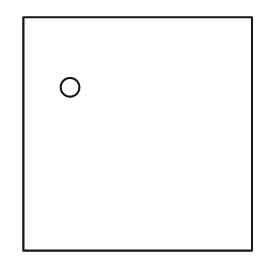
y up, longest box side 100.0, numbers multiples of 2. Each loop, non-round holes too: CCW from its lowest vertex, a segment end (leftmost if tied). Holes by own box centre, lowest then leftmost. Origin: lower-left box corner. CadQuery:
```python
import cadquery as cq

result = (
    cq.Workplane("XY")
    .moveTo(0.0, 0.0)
    .lineTo(98.0, 0.0)
    .lineTo(98.0, 100.0)
    .lineTo(0.0, 100.0)
    .close()
    .moveTo(20.0, 70.0)
    .circle(4.0)
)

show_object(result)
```